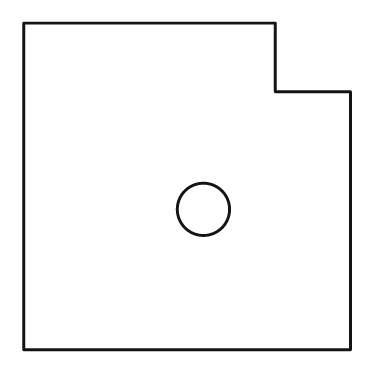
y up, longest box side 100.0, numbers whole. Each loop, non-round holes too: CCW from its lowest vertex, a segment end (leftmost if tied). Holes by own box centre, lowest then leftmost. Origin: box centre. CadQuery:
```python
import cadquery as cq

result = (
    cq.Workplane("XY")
    .moveTo(-50.0, -50.0)
    .lineTo(50.0, -50.0)
    .lineTo(50.0, 29.0)
    .lineTo(27.0, 29.0)
    .lineTo(27.0, 50.0)
    .lineTo(-50.0, 50.0)
    .close()
    .moveTo(5.0, -7.0)
    .circle(8.0)
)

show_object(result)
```